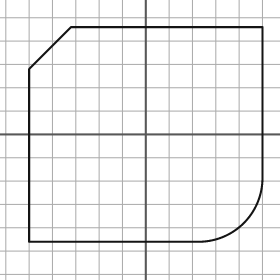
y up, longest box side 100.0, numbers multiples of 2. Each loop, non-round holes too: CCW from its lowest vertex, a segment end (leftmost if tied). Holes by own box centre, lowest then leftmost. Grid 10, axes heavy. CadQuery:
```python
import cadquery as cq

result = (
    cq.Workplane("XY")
    .moveTo(-50.0, -46.0)
    .lineTo(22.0, -46.0)
    .threePointArc((42.0, -38.0), (50.0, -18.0))
    .lineTo(50.0, 46.0)
    .lineTo(-32.0, 46.0)
    .lineTo(-50.0, 28.0)
    .close()
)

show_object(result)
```